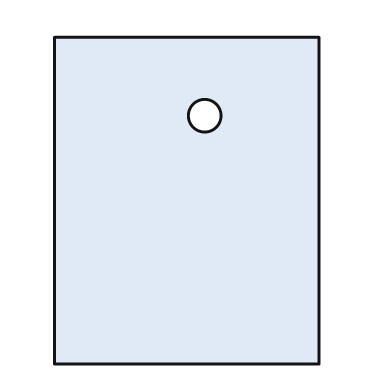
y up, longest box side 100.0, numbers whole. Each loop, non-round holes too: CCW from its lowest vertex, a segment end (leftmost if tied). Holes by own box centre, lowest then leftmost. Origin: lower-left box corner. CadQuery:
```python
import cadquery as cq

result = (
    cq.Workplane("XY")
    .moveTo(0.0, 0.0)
    .lineTo(81.0, 0.0)
    .lineTo(81.0, 100.0)
    .lineTo(0.0, 100.0)
    .close()
    .moveTo(46.0, 76.0)
    .circle(5.0)
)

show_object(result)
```